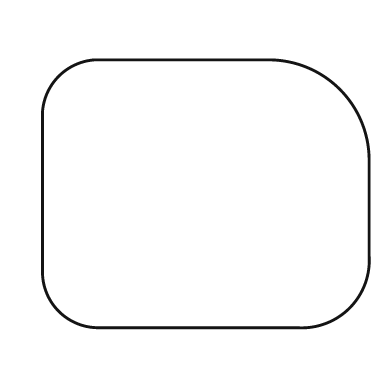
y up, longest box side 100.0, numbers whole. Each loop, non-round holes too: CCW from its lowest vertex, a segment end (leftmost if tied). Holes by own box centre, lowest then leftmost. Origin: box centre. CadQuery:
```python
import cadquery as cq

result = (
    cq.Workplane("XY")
    .moveTo(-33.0, -41.0)
    .lineTo(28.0, -41.0)
    .threePointArc((44.0, -35.0), (50.0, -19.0))
    .lineTo(50.0, 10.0)
    .threePointArc((41.0, 32.0), (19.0, 41.0))
    .lineTo(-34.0, 41.0)
    .threePointArc((-45.0, 36.0), (-50.0, 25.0))
    .lineTo(-50.0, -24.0)
    .threePointArc((-45.0, -36.0), (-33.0, -41.0))
    .close()
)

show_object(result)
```